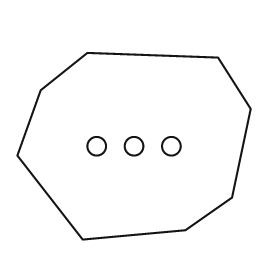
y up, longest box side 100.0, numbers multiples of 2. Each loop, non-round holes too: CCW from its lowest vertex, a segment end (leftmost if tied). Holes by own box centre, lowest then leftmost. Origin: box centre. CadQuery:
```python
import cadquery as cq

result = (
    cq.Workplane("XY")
    .moveTo(-22.0, -40.0)
    .lineTo(22.0, -36.0)
    .lineTo(42.0, -22.0)
    .lineTo(50.0, 16.0)
    .lineTo(36.0, 38.0)
    .lineTo(-20.0, 40.0)
    .lineTo(-40.0, 24.0)
    .lineTo(-50.0, -4.0)
    .close()
    .moveTo(-16.0, 0.0)
    .circle(4.0)
    .moveTo(0.0, 0.0)
    .circle(4.0)
    .moveTo(16.0, 0.0)
    .circle(4.0)
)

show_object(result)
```